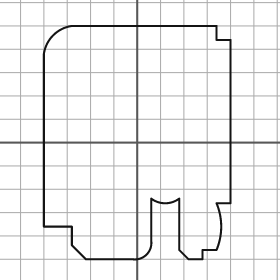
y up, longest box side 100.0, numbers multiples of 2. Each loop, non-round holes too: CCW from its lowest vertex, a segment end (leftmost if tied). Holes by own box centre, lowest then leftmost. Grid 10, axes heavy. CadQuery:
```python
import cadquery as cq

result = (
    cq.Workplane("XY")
    .moveTo(-22.0, -50.0)
    .lineTo(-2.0, -50.0)
    .threePointArc((4.0, -48.0), (6.0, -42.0))
    .lineTo(6.0, -24.0)
    .threePointArc((12.0, -26.0), (18.0, -24.0))
    .lineTo(18.0, -46.0)
    .lineTo(22.0, -50.0)
    .lineTo(28.0, -50.0)
    .lineTo(28.0, -46.0)
    .lineTo(34.0, -46.0)
    .threePointArc((36.0, -36.0), (34.0, -26.0))
    .lineTo(40.0, -26.0)
    .lineTo(40.0, 44.0)
    .lineTo(34.0, 44.0)
    .lineTo(34.0, 50.0)
    .lineTo(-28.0, 50.0)
    .threePointArc((-36.0, 46.0), (-40.0, 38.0))
    .lineTo(-40.0, -36.0)
    .lineTo(-28.0, -36.0)
    .lineTo(-28.0, -44.0)
    .close()
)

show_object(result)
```